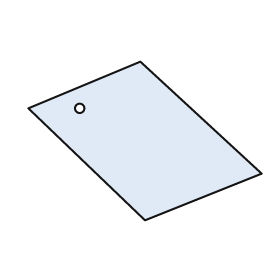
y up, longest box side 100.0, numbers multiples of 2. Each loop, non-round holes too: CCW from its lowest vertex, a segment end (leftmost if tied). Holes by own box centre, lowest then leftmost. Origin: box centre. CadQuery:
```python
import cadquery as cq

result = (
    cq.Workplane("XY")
    .moveTo(0.0, -34.0)
    .lineTo(50.0, -14.0)
    .lineTo(-2.0, 34.0)
    .lineTo(-50.0, 14.0)
    .close()
    .moveTo(-28.0, 14.0)
    .circle(2.0)
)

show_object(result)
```